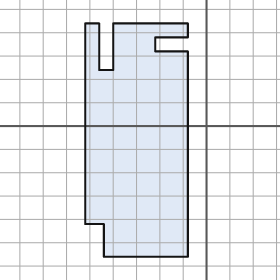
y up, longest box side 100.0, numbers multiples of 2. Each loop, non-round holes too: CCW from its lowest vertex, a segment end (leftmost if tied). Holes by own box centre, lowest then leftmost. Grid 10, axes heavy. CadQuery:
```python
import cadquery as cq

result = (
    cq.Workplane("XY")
    .moveTo(-44.0, -56.0)
    .lineTo(-8.0, -56.0)
    .lineTo(-8.0, 32.0)
    .lineTo(-22.0, 32.0)
    .lineTo(-22.0, 38.0)
    .lineTo(-8.0, 38.0)
    .lineTo(-8.0, 44.0)
    .lineTo(-40.0, 44.0)
    .lineTo(-40.0, 24.0)
    .lineTo(-46.0, 24.0)
    .lineTo(-46.0, 44.0)
    .lineTo(-52.0, 44.0)
    .lineTo(-52.0, -42.0)
    .lineTo(-44.0, -42.0)
    .close()
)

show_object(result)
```